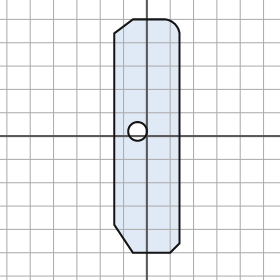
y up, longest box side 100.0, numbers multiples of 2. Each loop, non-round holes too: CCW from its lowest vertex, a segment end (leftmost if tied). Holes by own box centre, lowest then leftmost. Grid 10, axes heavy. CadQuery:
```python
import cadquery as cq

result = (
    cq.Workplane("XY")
    .moveTo(-6.0, -50.0)
    .lineTo(10.0, -50.0)
    .lineTo(14.0, -46.0)
    .lineTo(14.0, 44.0)
    .threePointArc((12.0, 48.0), (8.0, 50.0))
    .lineTo(-6.0, 50.0)
    .lineTo(-14.0, 44.0)
    .lineTo(-14.0, -38.0)
    .close()
    .moveTo(-4.0, 2.0)
    .circle(4.0)
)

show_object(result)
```